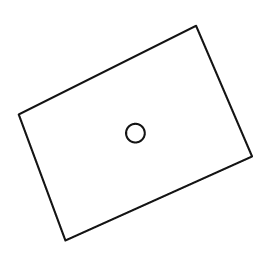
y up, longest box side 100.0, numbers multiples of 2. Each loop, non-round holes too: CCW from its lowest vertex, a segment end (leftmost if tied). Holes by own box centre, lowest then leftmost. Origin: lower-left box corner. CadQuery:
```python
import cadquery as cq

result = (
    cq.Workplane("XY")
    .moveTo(20.0, 0.0)
    .lineTo(100.0, 36.0)
    .lineTo(76.0, 92.0)
    .lineTo(0.0, 54.0)
    .close()
    .moveTo(50.0, 46.0)
    .circle(4.0)
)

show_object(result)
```